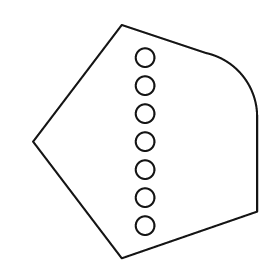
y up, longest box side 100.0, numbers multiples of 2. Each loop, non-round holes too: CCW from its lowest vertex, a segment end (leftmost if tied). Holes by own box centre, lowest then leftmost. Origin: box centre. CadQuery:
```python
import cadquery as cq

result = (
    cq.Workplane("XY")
    .moveTo(-10.0, -50.0)
    .lineTo(48.0, -30.0)
    .lineTo(48.0, 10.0)
    .threePointArc((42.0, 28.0), (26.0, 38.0))
    .lineTo(-10.0, 50.0)
    .lineTo(-48.0, 0.0)
    .close()
    .moveTo(0.0, -36.0)
    .circle(4.0)
    .moveTo(0.0, -24.0)
    .circle(4.0)
    .moveTo(0.0, -12.0)
    .circle(4.0)
    .moveTo(0.0, 0.0)
    .circle(4.0)
    .moveTo(0.0, 12.0)
    .circle(4.0)
    .moveTo(0.0, 24.0)
    .circle(4.0)
    .moveTo(0.0, 36.0)
    .circle(4.0)
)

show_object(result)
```